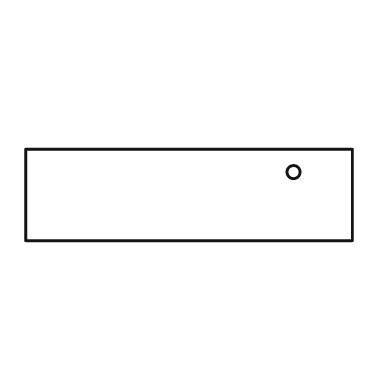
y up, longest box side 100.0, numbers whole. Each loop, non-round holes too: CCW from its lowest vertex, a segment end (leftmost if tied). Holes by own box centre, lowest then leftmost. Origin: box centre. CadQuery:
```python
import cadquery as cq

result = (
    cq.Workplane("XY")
    .moveTo(-50.0, -14.0)
    .lineTo(50.0, -14.0)
    .lineTo(50.0, 14.0)
    .lineTo(-50.0, 14.0)
    .close()
    .moveTo(32.0, 7.0)
    .circle(2.0)
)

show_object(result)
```